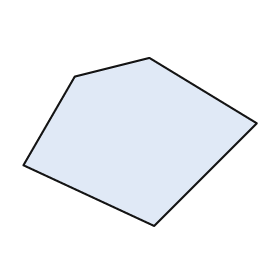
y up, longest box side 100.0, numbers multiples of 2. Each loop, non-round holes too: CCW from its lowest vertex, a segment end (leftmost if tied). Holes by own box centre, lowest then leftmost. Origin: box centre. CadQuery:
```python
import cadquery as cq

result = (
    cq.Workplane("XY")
    .moveTo(6.0, -36.0)
    .lineTo(50.0, 8.0)
    .lineTo(4.0, 36.0)
    .lineTo(-28.0, 28.0)
    .lineTo(-50.0, -10.0)
    .close()
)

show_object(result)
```